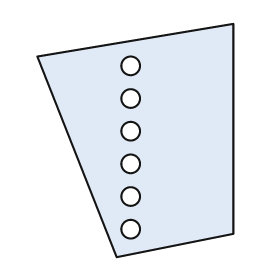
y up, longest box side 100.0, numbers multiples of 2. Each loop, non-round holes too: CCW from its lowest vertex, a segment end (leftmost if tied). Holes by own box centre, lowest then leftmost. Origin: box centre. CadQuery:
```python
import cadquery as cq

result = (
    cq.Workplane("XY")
    .moveTo(-8.0, -50.0)
    .lineTo(42.0, -40.0)
    .lineTo(42.0, 50.0)
    .lineTo(-42.0, 36.0)
    .close()
    .moveTo(-2.0, -38.0)
    .circle(4.0)
    .moveTo(-2.0, -24.0)
    .circle(4.0)
    .moveTo(-2.0, -10.0)
    .circle(4.0)
    .moveTo(-2.0, 4.0)
    .circle(4.0)
    .moveTo(-2.0, 18.0)
    .circle(4.0)
    .moveTo(-2.0, 32.0)
    .circle(4.0)
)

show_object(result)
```